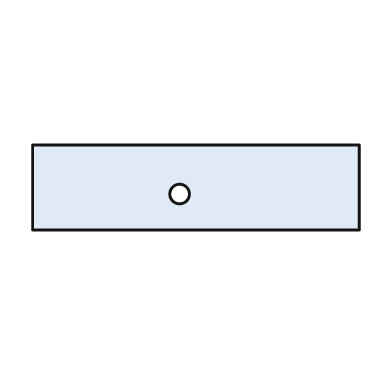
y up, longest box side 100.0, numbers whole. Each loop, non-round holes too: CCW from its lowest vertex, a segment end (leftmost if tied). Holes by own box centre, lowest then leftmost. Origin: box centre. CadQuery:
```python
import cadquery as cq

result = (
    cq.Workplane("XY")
    .moveTo(-50.0, -13.0)
    .lineTo(50.0, -13.0)
    .lineTo(50.0, 13.0)
    .lineTo(-50.0, 13.0)
    .close()
    .moveTo(-5.0, -2.0)
    .circle(3.0)
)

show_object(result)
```